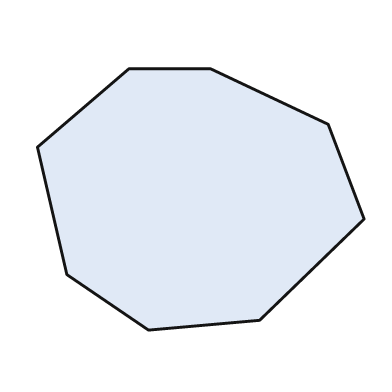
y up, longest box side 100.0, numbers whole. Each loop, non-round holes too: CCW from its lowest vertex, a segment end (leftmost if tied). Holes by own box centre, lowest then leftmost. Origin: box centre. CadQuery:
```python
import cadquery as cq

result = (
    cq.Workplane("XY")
    .moveTo(-16.0, -40.0)
    .lineTo(18.0, -37.0)
    .lineTo(50.0, -6.0)
    .lineTo(39.0, 23.0)
    .lineTo(3.0, 40.0)
    .lineTo(-22.0, 40.0)
    .lineTo(-50.0, 16.0)
    .lineTo(-41.0, -23.0)
    .close()
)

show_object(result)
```